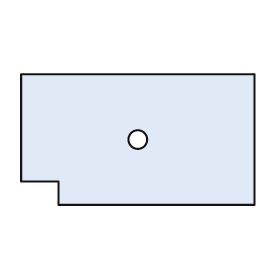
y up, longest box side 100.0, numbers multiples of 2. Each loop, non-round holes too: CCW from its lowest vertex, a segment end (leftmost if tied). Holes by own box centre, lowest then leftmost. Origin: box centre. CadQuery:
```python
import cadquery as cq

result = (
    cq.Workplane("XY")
    .moveTo(-34.0, -28.0)
    .lineTo(50.0, -28.0)
    .lineTo(50.0, 28.0)
    .lineTo(-50.0, 28.0)
    .lineTo(-50.0, -18.0)
    .lineTo(-34.0, -18.0)
    .close()
    .moveTo(0.0, 0.0)
    .circle(4.0)
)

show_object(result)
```